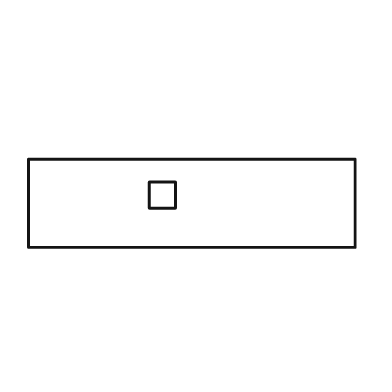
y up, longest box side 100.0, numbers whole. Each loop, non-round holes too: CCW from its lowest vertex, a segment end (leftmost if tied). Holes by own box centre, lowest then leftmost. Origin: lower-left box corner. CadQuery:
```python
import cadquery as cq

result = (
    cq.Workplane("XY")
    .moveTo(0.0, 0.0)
    .lineTo(100.0, 0.0)
    .lineTo(100.0, 27.0)
    .lineTo(0.0, 27.0)
    .close()
    .moveTo(37.0, 12.0)
    .lineTo(45.0, 12.0)
    .lineTo(45.0, 20.0)
    .lineTo(37.0, 20.0)
    .close()
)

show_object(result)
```